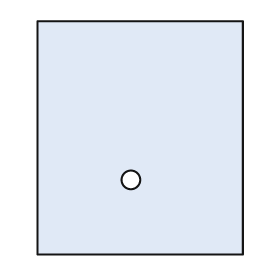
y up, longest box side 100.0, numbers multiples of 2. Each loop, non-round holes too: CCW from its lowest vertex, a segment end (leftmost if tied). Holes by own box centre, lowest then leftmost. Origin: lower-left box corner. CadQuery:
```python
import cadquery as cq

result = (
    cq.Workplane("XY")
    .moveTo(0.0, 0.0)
    .lineTo(88.0, 0.0)
    .lineTo(88.0, 100.0)
    .lineTo(0.0, 100.0)
    .close()
    .moveTo(40.0, 32.0)
    .circle(4.0)
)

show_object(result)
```